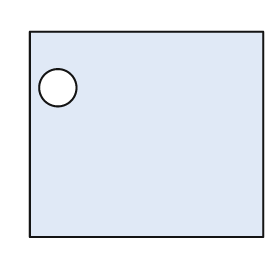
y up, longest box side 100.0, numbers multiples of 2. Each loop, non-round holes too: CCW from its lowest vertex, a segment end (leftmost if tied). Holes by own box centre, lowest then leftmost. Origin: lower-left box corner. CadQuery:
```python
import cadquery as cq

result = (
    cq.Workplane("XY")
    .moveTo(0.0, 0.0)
    .lineTo(100.0, 0.0)
    .lineTo(100.0, 88.0)
    .lineTo(0.0, 88.0)
    .close()
    .moveTo(12.0, 64.0)
    .circle(8.0)
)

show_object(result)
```